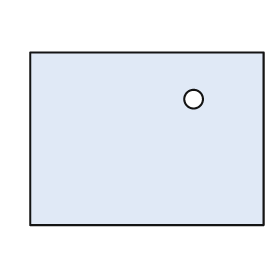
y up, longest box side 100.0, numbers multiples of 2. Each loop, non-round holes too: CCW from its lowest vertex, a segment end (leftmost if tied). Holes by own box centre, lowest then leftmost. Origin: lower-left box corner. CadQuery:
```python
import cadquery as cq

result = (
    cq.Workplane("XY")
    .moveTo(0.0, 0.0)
    .lineTo(100.0, 0.0)
    .lineTo(100.0, 74.0)
    .lineTo(0.0, 74.0)
    .close()
    .moveTo(70.0, 54.0)
    .circle(4.0)
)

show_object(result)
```